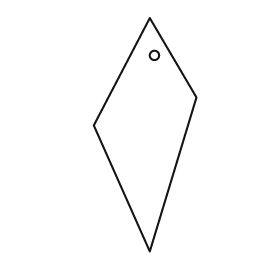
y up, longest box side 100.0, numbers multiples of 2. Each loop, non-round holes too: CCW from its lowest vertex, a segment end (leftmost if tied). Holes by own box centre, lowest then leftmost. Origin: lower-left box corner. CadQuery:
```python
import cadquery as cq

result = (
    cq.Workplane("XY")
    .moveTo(24.0, 0.0)
    .lineTo(44.0, 66.0)
    .lineTo(24.0, 100.0)
    .lineTo(0.0, 54.0)
    .close()
    .moveTo(26.0, 84.0)
    .circle(2.0)
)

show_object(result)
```